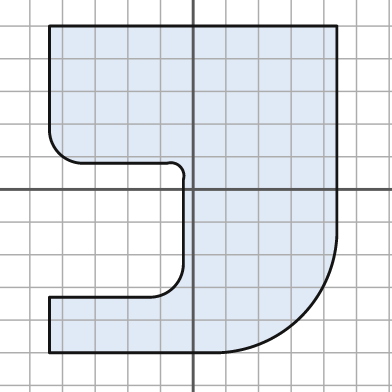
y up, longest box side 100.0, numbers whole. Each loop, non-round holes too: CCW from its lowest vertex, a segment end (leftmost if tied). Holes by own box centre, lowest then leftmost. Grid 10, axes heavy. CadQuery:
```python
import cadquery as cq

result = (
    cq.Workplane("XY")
    .moveTo(-44.0, -50.0)
    .lineTo(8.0, -50.0)
    .threePointArc((33.0, -39.0), (44.0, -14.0))
    .lineTo(44.0, 50.0)
    .lineTo(-44.0, 50.0)
    .lineTo(-44.0, 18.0)
    .threePointArc((-41.0, 11.0), (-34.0, 8.0))
    .lineTo(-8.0, 8.0)
    .threePointArc((-4.0, 7.0), (-3.0, 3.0))
    .lineTo(-3.0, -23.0)
    .threePointArc((-6.0, -30.0), (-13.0, -33.0))
    .lineTo(-44.0, -33.0)
    .close()
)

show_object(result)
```